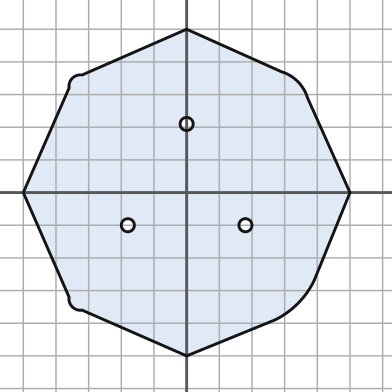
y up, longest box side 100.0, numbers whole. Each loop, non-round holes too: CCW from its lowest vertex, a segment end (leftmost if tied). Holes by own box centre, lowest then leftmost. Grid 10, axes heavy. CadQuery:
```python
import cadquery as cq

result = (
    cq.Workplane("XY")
    .moveTo(0.0, -50.0)
    .lineTo(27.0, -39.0)
    .threePointArc((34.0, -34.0), (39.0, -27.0))
    .lineTo(50.0, 0.0)
    .lineTo(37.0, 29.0)
    .threePointArc((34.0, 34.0), (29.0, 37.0))
    .lineTo(0.0, 50.0)
    .lineTo(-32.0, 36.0)
    .threePointArc((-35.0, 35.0), (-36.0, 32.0))
    .lineTo(-50.0, 0.0)
    .lineTo(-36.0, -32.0)
    .threePointArc((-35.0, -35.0), (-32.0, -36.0))
    .close()
    .moveTo(-18.0, -10.0)
    .circle(2.0)
    .moveTo(18.0, -10.0)
    .circle(2.0)
    .moveTo(0.0, 21.0)
    .circle(2.0)
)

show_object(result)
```